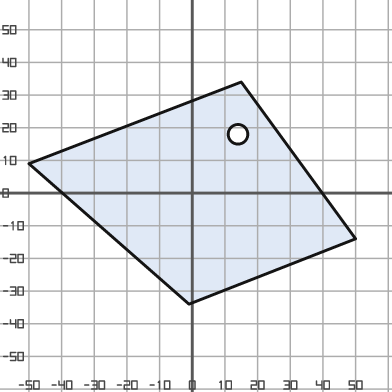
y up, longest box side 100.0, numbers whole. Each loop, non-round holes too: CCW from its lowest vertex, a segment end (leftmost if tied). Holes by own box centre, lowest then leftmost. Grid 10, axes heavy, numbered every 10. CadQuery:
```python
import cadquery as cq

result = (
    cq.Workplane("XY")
    .moveTo(-1.0, -34.0)
    .lineTo(50.0, -14.0)
    .lineTo(15.0, 34.0)
    .lineTo(-50.0, 9.0)
    .close()
    .moveTo(14.0, 18.0)
    .circle(3.0)
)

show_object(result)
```